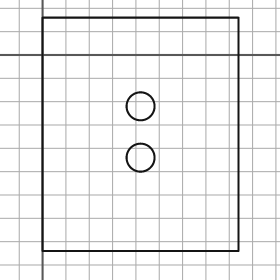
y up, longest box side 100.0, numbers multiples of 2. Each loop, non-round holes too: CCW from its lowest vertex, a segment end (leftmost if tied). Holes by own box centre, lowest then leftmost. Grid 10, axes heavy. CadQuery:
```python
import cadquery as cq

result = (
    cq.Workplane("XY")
    .moveTo(0.0, -84.0)
    .lineTo(84.0, -84.0)
    .lineTo(84.0, 16.0)
    .lineTo(0.0, 16.0)
    .close()
    .moveTo(42.0, -44.0)
    .circle(6.0)
    .moveTo(42.0, -22.0)
    .circle(6.0)
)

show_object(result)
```